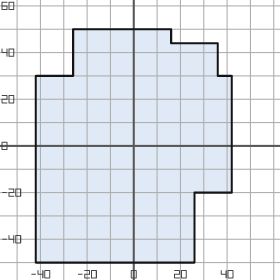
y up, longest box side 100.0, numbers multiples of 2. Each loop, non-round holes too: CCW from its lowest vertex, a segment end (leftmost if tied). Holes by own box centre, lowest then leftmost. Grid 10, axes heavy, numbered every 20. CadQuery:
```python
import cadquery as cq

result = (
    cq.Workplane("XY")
    .moveTo(-42.0, -50.0)
    .lineTo(26.0, -50.0)
    .lineTo(26.0, -20.0)
    .lineTo(42.0, -20.0)
    .lineTo(42.0, 30.0)
    .lineTo(36.0, 30.0)
    .lineTo(36.0, 44.0)
    .lineTo(16.0, 44.0)
    .lineTo(16.0, 50.0)
    .lineTo(-26.0, 50.0)
    .lineTo(-26.0, 30.0)
    .lineTo(-42.0, 30.0)
    .close()
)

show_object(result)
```